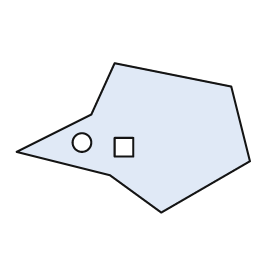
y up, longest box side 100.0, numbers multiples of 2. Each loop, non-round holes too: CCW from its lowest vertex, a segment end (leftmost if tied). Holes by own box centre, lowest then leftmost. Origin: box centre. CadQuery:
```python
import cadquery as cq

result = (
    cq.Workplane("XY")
    .moveTo(12.0, -32.0)
    .lineTo(50.0, -10.0)
    .lineTo(42.0, 22.0)
    .lineTo(-8.0, 32.0)
    .lineTo(-18.0, 10.0)
    .lineTo(-50.0, -6.0)
    .lineTo(-10.0, -16.0)
    .close()
    .moveTo(-8.0, -8.0)
    .lineTo(0.0, -8.0)
    .lineTo(0.0, 0.0)
    .lineTo(-8.0, 0.0)
    .close()
    .moveTo(-22.0, -2.0)
    .circle(4.0)
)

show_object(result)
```